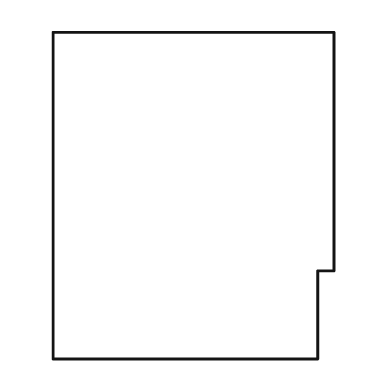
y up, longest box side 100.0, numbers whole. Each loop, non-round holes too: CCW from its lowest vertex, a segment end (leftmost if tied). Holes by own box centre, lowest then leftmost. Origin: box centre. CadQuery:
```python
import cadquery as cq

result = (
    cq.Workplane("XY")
    .moveTo(-43.0, -50.0)
    .lineTo(38.0, -50.0)
    .lineTo(38.0, -23.0)
    .lineTo(43.0, -23.0)
    .lineTo(43.0, 50.0)
    .lineTo(-43.0, 50.0)
    .close()
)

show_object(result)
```